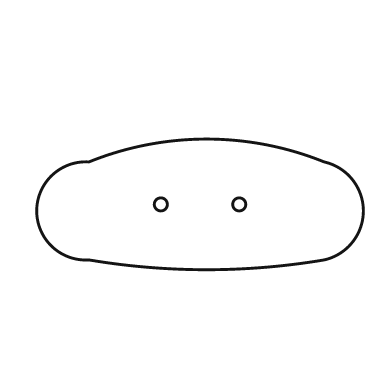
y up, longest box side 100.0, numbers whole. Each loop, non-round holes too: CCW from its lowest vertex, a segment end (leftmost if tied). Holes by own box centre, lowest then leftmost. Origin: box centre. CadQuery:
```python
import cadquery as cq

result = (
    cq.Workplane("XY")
    .moveTo(-34.0, -17.0)
    .threePointArc((2.0, -20.0), (38.0, -17.0))
    .threePointArc((50.0, -2.0), (38.0, 13.0))
    .threePointArc((2.0, 20.0), (-34.0, 13.0))
    .threePointArc((-50.0, -2.0), (-34.0, -17.0))
    .close()
    .moveTo(-12.0, 0.0)
    .circle(2.0)
    .moveTo(12.0, 0.0)
    .circle(2.0)
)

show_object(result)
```